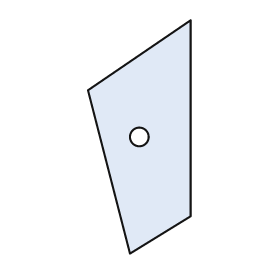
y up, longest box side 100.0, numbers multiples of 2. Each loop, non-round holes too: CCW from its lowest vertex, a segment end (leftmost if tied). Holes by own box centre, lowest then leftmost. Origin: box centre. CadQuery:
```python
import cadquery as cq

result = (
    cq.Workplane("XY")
    .moveTo(-4.0, -50.0)
    .lineTo(22.0, -34.0)
    .lineTo(22.0, 50.0)
    .lineTo(-22.0, 20.0)
    .close()
    .moveTo(0.0, 0.0)
    .circle(4.0)
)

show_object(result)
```